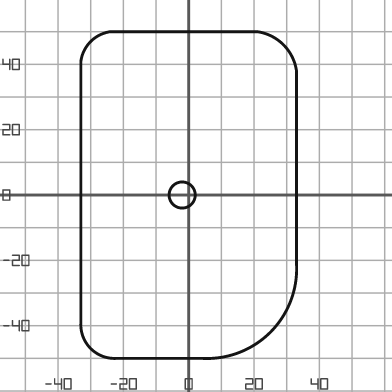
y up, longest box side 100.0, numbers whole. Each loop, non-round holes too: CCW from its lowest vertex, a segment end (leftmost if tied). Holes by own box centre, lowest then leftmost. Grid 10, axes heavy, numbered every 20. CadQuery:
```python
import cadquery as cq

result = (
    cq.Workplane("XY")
    .moveTo(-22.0, -50.0)
    .lineTo(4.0, -50.0)
    .threePointArc((25.0, -42.0), (33.0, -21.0))
    .lineTo(33.0, 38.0)
    .threePointArc((29.0, 46.0), (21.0, 50.0))
    .lineTo(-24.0, 50.0)
    .threePointArc((-30.0, 47.0), (-33.0, 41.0))
    .lineTo(-33.0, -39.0)
    .threePointArc((-30.0, -47.0), (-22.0, -50.0))
    .close()
    .moveTo(-2.0, 0.0)
    .circle(4.0)
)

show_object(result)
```